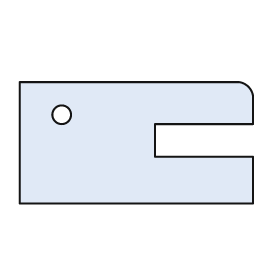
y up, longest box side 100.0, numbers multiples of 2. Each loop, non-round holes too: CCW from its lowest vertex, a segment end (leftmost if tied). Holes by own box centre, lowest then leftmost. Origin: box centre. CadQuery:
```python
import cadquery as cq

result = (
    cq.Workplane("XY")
    .moveTo(-50.0, -26.0)
    .lineTo(50.0, -26.0)
    .lineTo(50.0, -6.0)
    .lineTo(8.0, -6.0)
    .lineTo(8.0, 8.0)
    .lineTo(50.0, 8.0)
    .lineTo(50.0, 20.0)
    .threePointArc((48.0, 24.0), (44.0, 26.0))
    .lineTo(-50.0, 26.0)
    .close()
    .moveTo(-32.0, 12.0)
    .circle(4.0)
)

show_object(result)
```